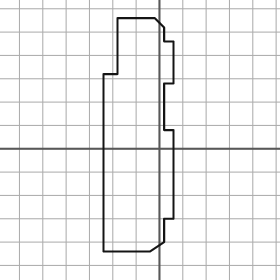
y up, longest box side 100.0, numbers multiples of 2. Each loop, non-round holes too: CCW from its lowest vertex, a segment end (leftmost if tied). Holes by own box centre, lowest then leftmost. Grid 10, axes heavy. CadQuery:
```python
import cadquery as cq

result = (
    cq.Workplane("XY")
    .moveTo(-24.0, -44.0)
    .lineTo(-4.0, -44.0)
    .lineTo(2.0, -40.0)
    .lineTo(2.0, -30.0)
    .lineTo(6.0, -30.0)
    .lineTo(6.0, 8.0)
    .lineTo(2.0, 8.0)
    .lineTo(2.0, 28.0)
    .lineTo(6.0, 28.0)
    .lineTo(6.0, 46.0)
    .lineTo(2.0, 46.0)
    .lineTo(2.0, 52.0)
    .lineTo(-2.0, 56.0)
    .lineTo(-18.0, 56.0)
    .lineTo(-18.0, 32.0)
    .lineTo(-24.0, 32.0)
    .close()
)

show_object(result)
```